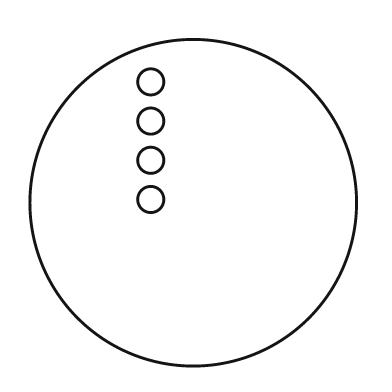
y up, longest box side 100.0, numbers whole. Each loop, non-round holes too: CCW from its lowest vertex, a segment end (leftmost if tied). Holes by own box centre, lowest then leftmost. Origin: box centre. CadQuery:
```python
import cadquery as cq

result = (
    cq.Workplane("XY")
    .moveTo(0.0, 0.0)
    .circle(50.0)
    .moveTo(-13.0, 1.0)
    .circle(4.0)
    .moveTo(-13.0, 13.0)
    .circle(4.0)
    .moveTo(-13.0, 25.0)
    .circle(4.0)
    .moveTo(-13.0, 37.0)
    .circle(4.0)
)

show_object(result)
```